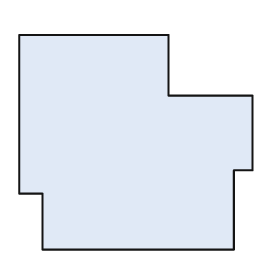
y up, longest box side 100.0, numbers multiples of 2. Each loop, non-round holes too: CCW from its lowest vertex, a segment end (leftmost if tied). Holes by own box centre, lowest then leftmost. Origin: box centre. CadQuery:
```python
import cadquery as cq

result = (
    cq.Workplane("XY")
    .moveTo(-40.0, -46.0)
    .lineTo(42.0, -46.0)
    .lineTo(42.0, -12.0)
    .lineTo(50.0, -12.0)
    .lineTo(50.0, 20.0)
    .lineTo(14.0, 20.0)
    .lineTo(14.0, 46.0)
    .lineTo(-50.0, 46.0)
    .lineTo(-50.0, -22.0)
    .lineTo(-40.0, -22.0)
    .close()
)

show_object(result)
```